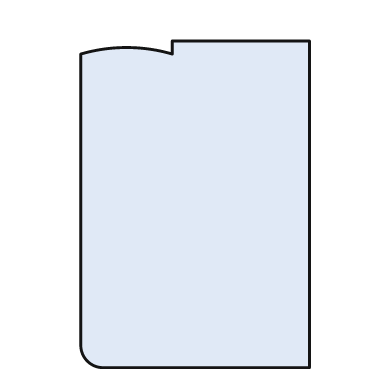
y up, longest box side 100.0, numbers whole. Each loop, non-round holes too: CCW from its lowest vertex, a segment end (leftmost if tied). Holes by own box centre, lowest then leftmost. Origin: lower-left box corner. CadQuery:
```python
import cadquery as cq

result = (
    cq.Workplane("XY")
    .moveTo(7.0, 0.0)
    .lineTo(70.0, 0.0)
    .lineTo(70.0, 100.0)
    .lineTo(28.0, 100.0)
    .lineTo(28.0, 96.0)
    .threePointArc((14.0, 98.0), (0.0, 96.0))
    .lineTo(0.0, 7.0)
    .threePointArc((2.0, 2.0), (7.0, 0.0))
    .close()
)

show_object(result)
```